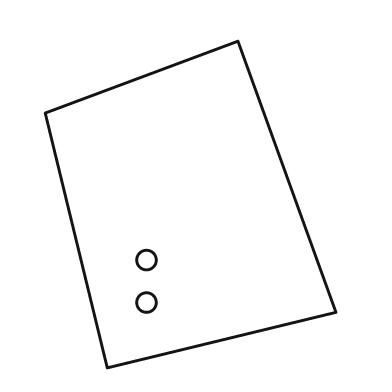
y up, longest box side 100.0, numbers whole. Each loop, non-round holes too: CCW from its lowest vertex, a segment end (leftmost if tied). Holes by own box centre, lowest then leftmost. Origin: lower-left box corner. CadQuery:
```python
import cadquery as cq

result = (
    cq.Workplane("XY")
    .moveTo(19.0, 0.0)
    .lineTo(89.0, 17.0)
    .lineTo(59.0, 100.0)
    .lineTo(0.0, 78.0)
    .close()
    .moveTo(31.0, 20.0)
    .circle(3.0)
    .moveTo(31.0, 33.0)
    .circle(3.0)
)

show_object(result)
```